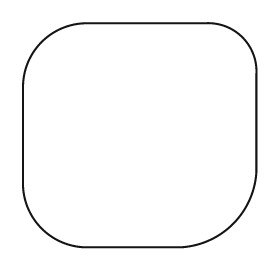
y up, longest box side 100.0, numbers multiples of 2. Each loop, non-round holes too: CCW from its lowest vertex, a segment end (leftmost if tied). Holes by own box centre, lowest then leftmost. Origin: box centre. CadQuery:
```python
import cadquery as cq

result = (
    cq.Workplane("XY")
    .moveTo(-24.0, -48.0)
    .lineTo(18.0, -48.0)
    .threePointArc((40.0, -38.0), (50.0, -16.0))
    .lineTo(50.0, 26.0)
    .threePointArc((44.0, 42.0), (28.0, 48.0))
    .lineTo(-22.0, 48.0)
    .threePointArc((-42.0, 40.0), (-50.0, 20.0))
    .lineTo(-50.0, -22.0)
    .threePointArc((-42.0, -40.0), (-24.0, -48.0))
    .close()
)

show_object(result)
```